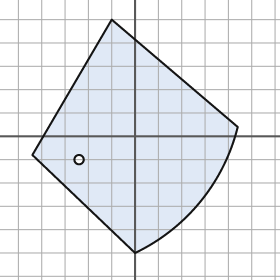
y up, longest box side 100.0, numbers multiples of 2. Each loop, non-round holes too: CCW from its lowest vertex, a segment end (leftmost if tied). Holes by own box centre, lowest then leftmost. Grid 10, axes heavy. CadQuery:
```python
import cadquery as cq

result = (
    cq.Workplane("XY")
    .moveTo(0.0, -50.0)
    .threePointArc((28.0, -28.0), (44.0, 4.0))
    .lineTo(-10.0, 50.0)
    .lineTo(-44.0, -8.0)
    .close()
    .moveTo(-24.0, -10.0)
    .circle(2.0)
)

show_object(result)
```